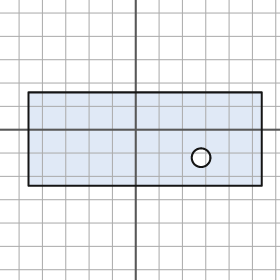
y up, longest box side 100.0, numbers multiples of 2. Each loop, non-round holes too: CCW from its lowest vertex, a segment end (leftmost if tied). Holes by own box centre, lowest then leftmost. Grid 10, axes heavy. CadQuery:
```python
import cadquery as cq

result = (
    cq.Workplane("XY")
    .moveTo(-46.0, -24.0)
    .lineTo(54.0, -24.0)
    .lineTo(54.0, 16.0)
    .lineTo(-46.0, 16.0)
    .close()
    .moveTo(28.0, -12.0)
    .circle(4.0)
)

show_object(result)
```